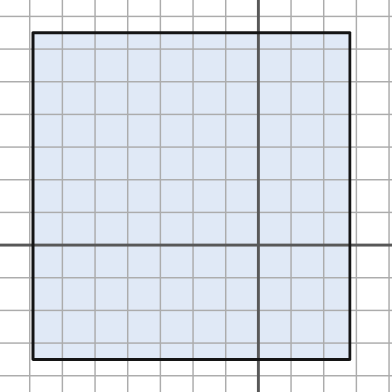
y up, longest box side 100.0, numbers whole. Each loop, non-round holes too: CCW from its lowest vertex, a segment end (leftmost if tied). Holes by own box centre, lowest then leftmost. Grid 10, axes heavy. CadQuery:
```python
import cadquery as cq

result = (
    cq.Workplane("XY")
    .moveTo(-69.0, -35.0)
    .lineTo(28.0, -35.0)
    .lineTo(28.0, 65.0)
    .lineTo(-69.0, 65.0)
    .close()
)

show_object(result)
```